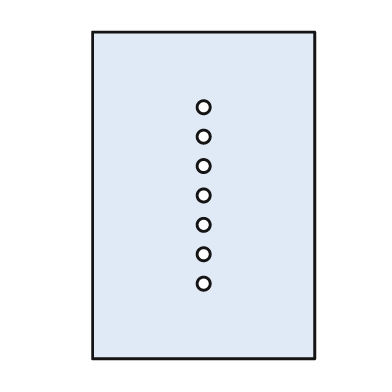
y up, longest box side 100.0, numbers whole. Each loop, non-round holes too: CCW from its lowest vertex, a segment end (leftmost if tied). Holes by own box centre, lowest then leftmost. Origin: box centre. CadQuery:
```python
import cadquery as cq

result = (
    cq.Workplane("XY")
    .moveTo(-34.0, -50.0)
    .lineTo(34.0, -50.0)
    .lineTo(34.0, 50.0)
    .lineTo(-34.0, 50.0)
    .close()
    .moveTo(0.0, -27.0)
    .circle(2.0)
    .moveTo(0.0, -18.0)
    .circle(2.0)
    .moveTo(0.0, -9.0)
    .circle(2.0)
    .moveTo(0.0, 0.0)
    .circle(2.0)
    .moveTo(0.0, 9.0)
    .circle(2.0)
    .moveTo(0.0, 18.0)
    .circle(2.0)
    .moveTo(0.0, 27.0)
    .circle(2.0)
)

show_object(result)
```